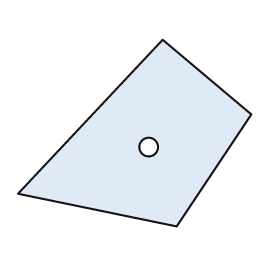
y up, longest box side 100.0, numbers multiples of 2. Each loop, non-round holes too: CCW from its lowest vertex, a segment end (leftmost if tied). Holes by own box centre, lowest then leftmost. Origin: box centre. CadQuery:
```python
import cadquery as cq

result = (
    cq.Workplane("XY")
    .moveTo(18.0, -40.0)
    .lineTo(50.0, 8.0)
    .lineTo(12.0, 40.0)
    .lineTo(-50.0, -26.0)
    .close()
    .moveTo(6.0, -6.0)
    .circle(4.0)
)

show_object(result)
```